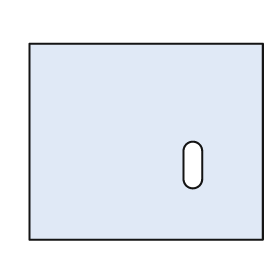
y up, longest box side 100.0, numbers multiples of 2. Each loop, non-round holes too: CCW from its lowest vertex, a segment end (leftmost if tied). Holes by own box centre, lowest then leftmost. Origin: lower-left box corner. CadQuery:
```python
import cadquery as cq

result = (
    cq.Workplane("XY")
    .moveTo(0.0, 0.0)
    .lineTo(100.0, 0.0)
    .lineTo(100.0, 84.0)
    .lineTo(0.0, 84.0)
    .close()
    .moveTo(66.0, 26.0)
    .threePointArc((70.0, 22.0), (74.0, 26.0))
    .lineTo(74.0, 38.0)
    .threePointArc((70.0, 42.0), (66.0, 38.0))
    .close()
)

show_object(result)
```